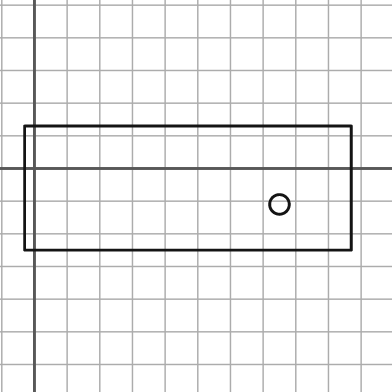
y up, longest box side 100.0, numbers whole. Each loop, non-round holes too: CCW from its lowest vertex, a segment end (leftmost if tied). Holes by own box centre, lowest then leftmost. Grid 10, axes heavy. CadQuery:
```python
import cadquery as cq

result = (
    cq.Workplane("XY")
    .moveTo(-3.0, -25.0)
    .lineTo(97.0, -25.0)
    .lineTo(97.0, 13.0)
    .lineTo(-3.0, 13.0)
    .close()
    .moveTo(75.0, -11.0)
    .circle(3.0)
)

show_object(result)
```